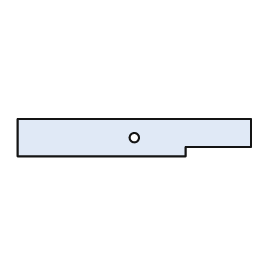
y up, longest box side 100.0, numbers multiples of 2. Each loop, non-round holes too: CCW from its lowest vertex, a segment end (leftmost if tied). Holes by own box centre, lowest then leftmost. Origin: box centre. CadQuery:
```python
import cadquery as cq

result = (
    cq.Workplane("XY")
    .moveTo(-50.0, -8.0)
    .lineTo(22.0, -8.0)
    .lineTo(22.0, -4.0)
    .lineTo(50.0, -4.0)
    .lineTo(50.0, 8.0)
    .lineTo(-50.0, 8.0)
    .close()
    .moveTo(0.0, 0.0)
    .circle(2.0)
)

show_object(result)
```